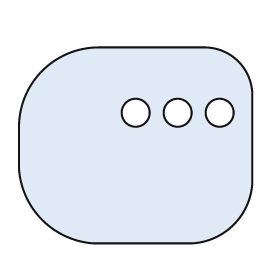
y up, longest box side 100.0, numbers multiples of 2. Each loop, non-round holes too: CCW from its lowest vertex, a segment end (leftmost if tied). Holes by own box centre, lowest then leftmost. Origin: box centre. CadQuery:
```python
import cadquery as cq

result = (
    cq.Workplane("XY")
    .moveTo(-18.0, -42.0)
    .lineTo(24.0, -42.0)
    .threePointArc((42.0, -34.0), (50.0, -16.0))
    .lineTo(50.0, 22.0)
    .threePointArc((44.0, 36.0), (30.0, 42.0))
    .lineTo(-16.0, 42.0)
    .threePointArc((-40.0, 32.0), (-50.0, 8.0))
    .lineTo(-50.0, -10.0)
    .threePointArc((-40.0, -32.0), (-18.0, -42.0))
    .close()
    .moveTo(0.0, 14.0)
    .circle(6.0)
    .moveTo(18.0, 14.0)
    .circle(6.0)
    .moveTo(36.0, 14.0)
    .circle(6.0)
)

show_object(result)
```